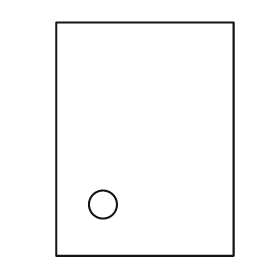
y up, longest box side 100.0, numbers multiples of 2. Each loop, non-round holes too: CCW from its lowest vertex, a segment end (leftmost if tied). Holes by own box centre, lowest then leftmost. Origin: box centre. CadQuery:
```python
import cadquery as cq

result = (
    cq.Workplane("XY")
    .moveTo(-38.0, -50.0)
    .lineTo(38.0, -50.0)
    .lineTo(38.0, 50.0)
    .lineTo(-38.0, 50.0)
    .close()
    .moveTo(-18.0, -28.0)
    .circle(6.0)
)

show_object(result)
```